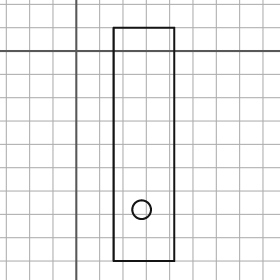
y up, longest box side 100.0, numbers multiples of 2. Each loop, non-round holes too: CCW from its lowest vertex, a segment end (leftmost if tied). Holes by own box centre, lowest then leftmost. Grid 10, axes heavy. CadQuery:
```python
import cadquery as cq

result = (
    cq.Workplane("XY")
    .moveTo(16.0, -90.0)
    .lineTo(42.0, -90.0)
    .lineTo(42.0, 10.0)
    .lineTo(16.0, 10.0)
    .close()
    .moveTo(28.0, -68.0)
    .circle(4.0)
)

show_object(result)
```